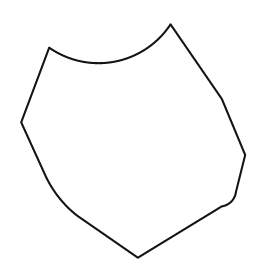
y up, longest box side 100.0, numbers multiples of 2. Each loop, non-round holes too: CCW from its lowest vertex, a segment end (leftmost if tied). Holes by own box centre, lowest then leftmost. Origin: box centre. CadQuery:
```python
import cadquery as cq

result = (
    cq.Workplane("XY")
    .moveTo(2.0, -50.0)
    .lineTo(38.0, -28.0)
    .threePointArc((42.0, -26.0), (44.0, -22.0))
    .lineTo(48.0, -6.0)
    .lineTo(38.0, 18.0)
    .lineTo(16.0, 50.0)
    .threePointArc((-8.0, 34.0), (-36.0, 40.0))
    .lineTo(-48.0, 8.0)
    .lineTo(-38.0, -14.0)
    .threePointArc((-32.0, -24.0), (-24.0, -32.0))
    .close()
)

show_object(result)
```